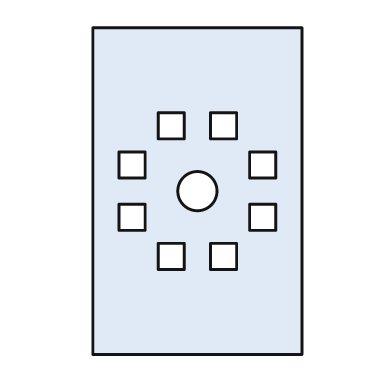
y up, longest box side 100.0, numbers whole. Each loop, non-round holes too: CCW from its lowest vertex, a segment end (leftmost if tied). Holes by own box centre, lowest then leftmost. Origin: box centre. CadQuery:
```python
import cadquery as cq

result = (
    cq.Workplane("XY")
    .moveTo(-32.0, -50.0)
    .lineTo(32.0, -50.0)
    .lineTo(32.0, 50.0)
    .lineTo(-32.0, 50.0)
    .close()
    .moveTo(-12.0, -24.0)
    .lineTo(-4.0, -24.0)
    .lineTo(-4.0, -16.0)
    .lineTo(-12.0, -16.0)
    .close()
    .moveTo(4.0, -24.0)
    .lineTo(12.0, -24.0)
    .lineTo(12.0, -16.0)
    .lineTo(4.0, -16.0)
    .close()
    .moveTo(-24.0, -12.0)
    .lineTo(-16.0, -12.0)
    .lineTo(-16.0, -4.0)
    .lineTo(-24.0, -4.0)
    .close()
    .moveTo(16.0, -12.0)
    .lineTo(24.0, -12.0)
    .lineTo(24.0, -4.0)
    .lineTo(16.0, -4.0)
    .close()
    .moveTo(0.0, 0.0)
    .circle(6.0)
    .moveTo(-24.0, 4.0)
    .lineTo(-16.0, 4.0)
    .lineTo(-16.0, 12.0)
    .lineTo(-24.0, 12.0)
    .close()
    .moveTo(16.0, 4.0)
    .lineTo(24.0, 4.0)
    .lineTo(24.0, 12.0)
    .lineTo(16.0, 12.0)
    .close()
    .moveTo(-12.0, 16.0)
    .lineTo(-4.0, 16.0)
    .lineTo(-4.0, 24.0)
    .lineTo(-12.0, 24.0)
    .close()
    .moveTo(4.0, 16.0)
    .lineTo(12.0, 16.0)
    .lineTo(12.0, 24.0)
    .lineTo(4.0, 24.0)
    .close()
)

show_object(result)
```